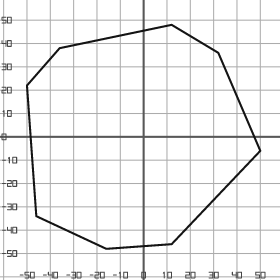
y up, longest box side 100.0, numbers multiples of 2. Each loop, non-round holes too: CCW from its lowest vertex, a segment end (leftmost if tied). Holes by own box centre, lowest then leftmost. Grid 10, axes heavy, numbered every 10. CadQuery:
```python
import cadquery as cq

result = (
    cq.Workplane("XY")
    .moveTo(-16.0, -48.0)
    .lineTo(12.0, -46.0)
    .lineTo(50.0, -6.0)
    .lineTo(32.0, 36.0)
    .lineTo(12.0, 48.0)
    .lineTo(-36.0, 38.0)
    .lineTo(-50.0, 22.0)
    .lineTo(-46.0, -34.0)
    .close()
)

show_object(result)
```